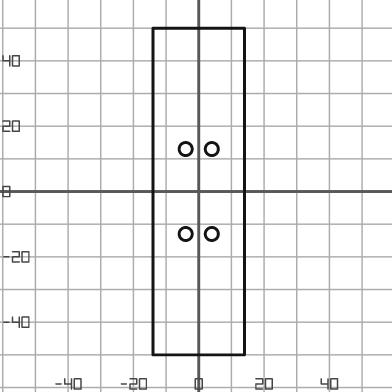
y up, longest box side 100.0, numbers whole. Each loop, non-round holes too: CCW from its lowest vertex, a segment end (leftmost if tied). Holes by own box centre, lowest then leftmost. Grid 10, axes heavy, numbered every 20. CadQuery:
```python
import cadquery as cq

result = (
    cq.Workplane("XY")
    .moveTo(-14.0, -50.0)
    .lineTo(14.0, -50.0)
    .lineTo(14.0, 50.0)
    .lineTo(-14.0, 50.0)
    .close()
    .moveTo(-4.0, -13.0)
    .circle(2.0)
    .moveTo(4.0, -13.0)
    .circle(2.0)
    .moveTo(-4.0, 13.0)
    .circle(2.0)
    .moveTo(4.0, 13.0)
    .circle(2.0)
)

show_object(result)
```